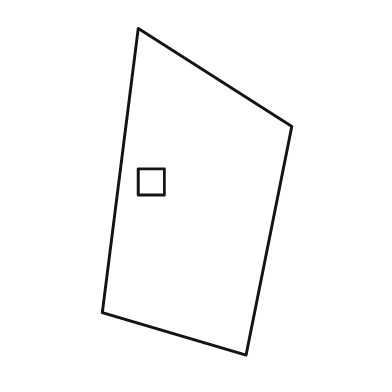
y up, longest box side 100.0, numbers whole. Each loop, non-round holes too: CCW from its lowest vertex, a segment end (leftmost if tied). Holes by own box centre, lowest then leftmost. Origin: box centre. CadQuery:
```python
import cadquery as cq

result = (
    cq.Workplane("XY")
    .moveTo(15.0, -50.0)
    .lineTo(29.0, 20.0)
    .lineTo(-18.0, 50.0)
    .lineTo(-29.0, -37.0)
    .close()
    .moveTo(-18.0, -1.0)
    .lineTo(-10.0, -1.0)
    .lineTo(-10.0, 7.0)
    .lineTo(-18.0, 7.0)
    .close()
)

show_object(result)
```